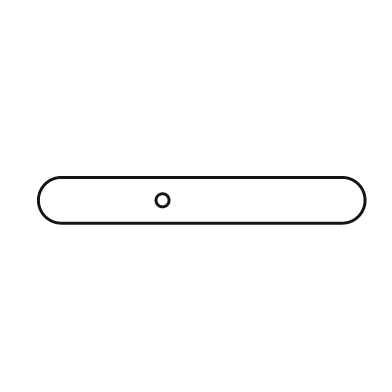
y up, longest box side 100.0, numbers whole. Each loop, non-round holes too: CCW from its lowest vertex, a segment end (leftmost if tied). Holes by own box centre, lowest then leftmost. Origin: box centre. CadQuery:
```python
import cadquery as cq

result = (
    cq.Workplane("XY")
    .moveTo(-43.0, -7.0)
    .lineTo(43.0, -7.0)
    .threePointArc((50.0, 0.0), (43.0, 7.0))
    .lineTo(-43.0, 7.0)
    .threePointArc((-50.0, 0.0), (-43.0, -7.0))
    .close()
    .moveTo(-12.0, 0.0)
    .circle(2.0)
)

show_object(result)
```